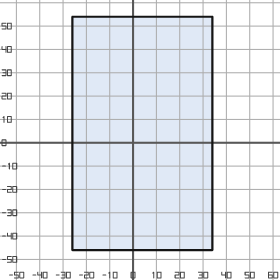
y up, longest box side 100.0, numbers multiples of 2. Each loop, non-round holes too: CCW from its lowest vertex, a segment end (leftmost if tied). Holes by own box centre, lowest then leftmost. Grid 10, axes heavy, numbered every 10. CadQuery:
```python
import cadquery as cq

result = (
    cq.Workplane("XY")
    .moveTo(-26.0, -46.0)
    .lineTo(34.0, -46.0)
    .lineTo(34.0, 54.0)
    .lineTo(-26.0, 54.0)
    .close()
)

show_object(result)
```